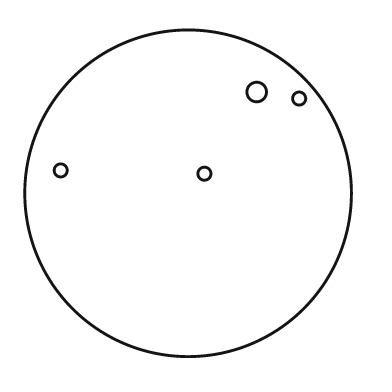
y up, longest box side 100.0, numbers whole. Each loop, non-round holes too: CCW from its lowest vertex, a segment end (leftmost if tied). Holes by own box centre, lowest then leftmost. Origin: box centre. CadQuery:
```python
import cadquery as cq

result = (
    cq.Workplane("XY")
    .moveTo(0.0, 0.0)
    .circle(50.0)
    .moveTo(5.0, 6.0)
    .circle(2.0)
    .moveTo(-39.0, 7.0)
    .circle(2.0)
    .moveTo(34.0, 29.0)
    .circle(2.0)
    .moveTo(21.0, 31.0)
    .circle(3.0)
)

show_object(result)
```